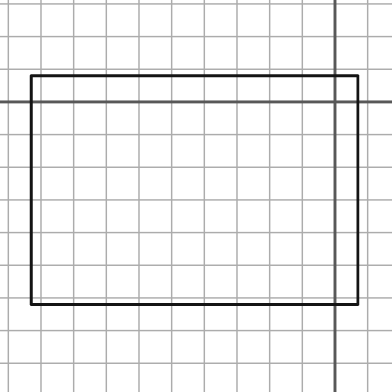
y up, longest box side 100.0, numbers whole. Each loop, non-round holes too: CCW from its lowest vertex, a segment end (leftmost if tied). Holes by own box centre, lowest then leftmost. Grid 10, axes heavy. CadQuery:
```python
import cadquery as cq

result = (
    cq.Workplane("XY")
    .moveTo(-93.0, -62.0)
    .lineTo(7.0, -62.0)
    .lineTo(7.0, 8.0)
    .lineTo(-93.0, 8.0)
    .close()
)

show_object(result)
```